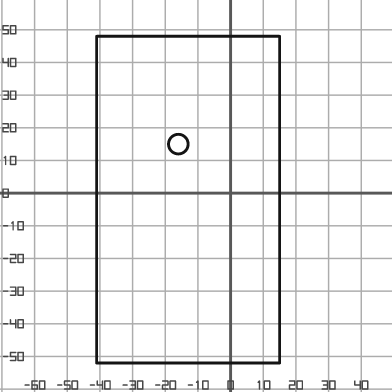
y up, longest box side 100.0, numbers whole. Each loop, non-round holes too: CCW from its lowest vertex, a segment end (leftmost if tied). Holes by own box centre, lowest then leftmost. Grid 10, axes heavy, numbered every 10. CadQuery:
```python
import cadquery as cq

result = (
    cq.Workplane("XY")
    .moveTo(-41.0, -52.0)
    .lineTo(15.0, -52.0)
    .lineTo(15.0, 48.0)
    .lineTo(-41.0, 48.0)
    .close()
    .moveTo(-16.0, 15.0)
    .circle(3.0)
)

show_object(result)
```